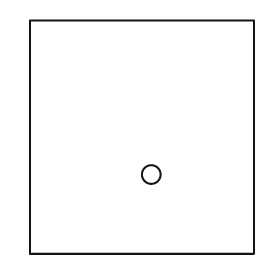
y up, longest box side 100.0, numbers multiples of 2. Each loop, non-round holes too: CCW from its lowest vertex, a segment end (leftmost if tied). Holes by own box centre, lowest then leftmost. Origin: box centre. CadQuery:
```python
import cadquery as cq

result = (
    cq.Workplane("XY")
    .moveTo(-48.0, -50.0)
    .lineTo(48.0, -50.0)
    .lineTo(48.0, 50.0)
    .lineTo(-48.0, 50.0)
    .close()
    .moveTo(4.0, -16.0)
    .circle(4.0)
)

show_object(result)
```